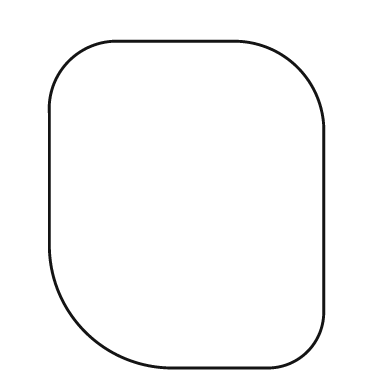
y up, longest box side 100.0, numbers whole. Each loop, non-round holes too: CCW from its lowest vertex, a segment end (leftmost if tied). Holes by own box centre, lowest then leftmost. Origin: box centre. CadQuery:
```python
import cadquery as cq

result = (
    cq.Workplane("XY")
    .moveTo(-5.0, -50.0)
    .lineTo(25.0, -50.0)
    .threePointArc((37.0, -45.0), (42.0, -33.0))
    .lineTo(42.0, 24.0)
    .threePointArc((34.0, 42.0), (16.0, 50.0))
    .lineTo(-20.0, 50.0)
    .threePointArc((-36.0, 44.0), (-42.0, 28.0))
    .lineTo(-42.0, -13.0)
    .threePointArc((-31.0, -39.0), (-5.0, -50.0))
    .close()
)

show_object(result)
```